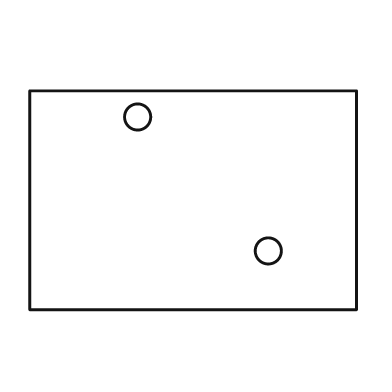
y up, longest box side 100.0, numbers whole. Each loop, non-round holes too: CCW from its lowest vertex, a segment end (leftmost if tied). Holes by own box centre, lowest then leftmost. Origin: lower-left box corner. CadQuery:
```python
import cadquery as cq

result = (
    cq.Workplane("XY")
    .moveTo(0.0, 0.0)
    .lineTo(100.0, 0.0)
    .lineTo(100.0, 67.0)
    .lineTo(0.0, 67.0)
    .close()
    .moveTo(73.0, 18.0)
    .circle(4.0)
    .moveTo(33.0, 59.0)
    .circle(4.0)
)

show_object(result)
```